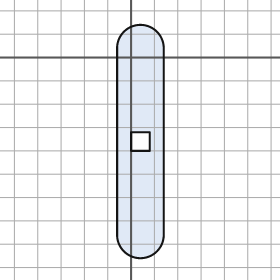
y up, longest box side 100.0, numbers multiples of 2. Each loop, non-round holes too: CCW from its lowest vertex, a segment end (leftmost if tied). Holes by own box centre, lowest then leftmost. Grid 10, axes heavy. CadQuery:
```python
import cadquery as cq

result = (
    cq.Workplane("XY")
    .moveTo(-6.0, -76.0)
    .threePointArc((4.0, -86.0), (14.0, -76.0))
    .lineTo(14.0, 4.0)
    .threePointArc((4.0, 14.0), (-6.0, 4.0))
    .close()
    .moveTo(0.0, -40.0)
    .lineTo(8.0, -40.0)
    .lineTo(8.0, -32.0)
    .lineTo(0.0, -32.0)
    .close()
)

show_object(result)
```